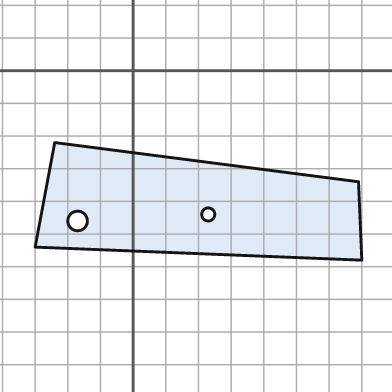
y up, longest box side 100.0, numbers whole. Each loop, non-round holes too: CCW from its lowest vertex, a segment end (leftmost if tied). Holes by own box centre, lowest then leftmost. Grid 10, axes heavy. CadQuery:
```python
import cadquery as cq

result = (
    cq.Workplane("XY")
    .moveTo(70.0, -58.0)
    .lineTo(69.0, -34.0)
    .lineTo(-24.0, -22.0)
    .lineTo(-30.0, -54.0)
    .close()
    .moveTo(-17.0, -46.0)
    .circle(3.0)
    .moveTo(23.0, -44.0)
    .circle(2.0)
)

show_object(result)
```